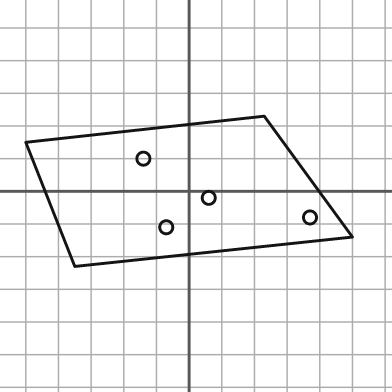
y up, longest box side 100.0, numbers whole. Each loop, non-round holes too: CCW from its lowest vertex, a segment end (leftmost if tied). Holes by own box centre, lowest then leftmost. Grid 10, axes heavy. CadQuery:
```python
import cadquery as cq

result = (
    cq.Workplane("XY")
    .moveTo(-35.0, -23.0)
    .lineTo(50.0, -14.0)
    .lineTo(23.0, 23.0)
    .lineTo(-50.0, 15.0)
    .close()
    .moveTo(-7.0, -11.0)
    .circle(2.0)
    .moveTo(37.0, -8.0)
    .circle(2.0)
    .moveTo(6.0, -2.0)
    .circle(2.0)
    .moveTo(-14.0, 10.0)
    .circle(2.0)
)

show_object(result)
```